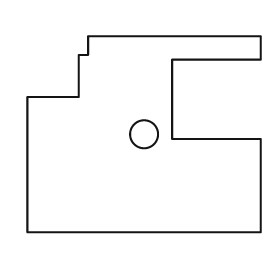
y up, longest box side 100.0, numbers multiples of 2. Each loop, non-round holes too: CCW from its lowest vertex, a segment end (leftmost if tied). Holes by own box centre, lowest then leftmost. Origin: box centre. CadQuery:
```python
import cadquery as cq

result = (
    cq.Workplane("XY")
    .moveTo(-50.0, -42.0)
    .lineTo(50.0, -42.0)
    .lineTo(50.0, -2.0)
    .lineTo(12.0, -2.0)
    .lineTo(12.0, 32.0)
    .lineTo(50.0, 32.0)
    .lineTo(50.0, 42.0)
    .lineTo(-24.0, 42.0)
    .lineTo(-24.0, 34.0)
    .lineTo(-28.0, 34.0)
    .lineTo(-28.0, 16.0)
    .lineTo(-50.0, 16.0)
    .close()
    .moveTo(0.0, 0.0)
    .circle(6.0)
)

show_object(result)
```